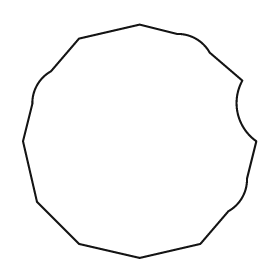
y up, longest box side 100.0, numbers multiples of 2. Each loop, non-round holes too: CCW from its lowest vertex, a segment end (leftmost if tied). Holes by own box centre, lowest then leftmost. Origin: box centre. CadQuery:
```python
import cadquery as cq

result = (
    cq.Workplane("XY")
    .moveTo(0.0, -50.0)
    .lineTo(26.0, -44.0)
    .lineTo(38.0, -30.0)
    .threePointArc((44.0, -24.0), (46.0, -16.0))
    .lineTo(50.0, 0.0)
    .threePointArc((42.0, 12.0), (44.0, 26.0))
    .lineTo(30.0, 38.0)
    .threePointArc((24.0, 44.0), (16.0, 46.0))
    .lineTo(0.0, 50.0)
    .lineTo(-26.0, 44.0)
    .lineTo(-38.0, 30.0)
    .threePointArc((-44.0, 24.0), (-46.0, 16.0))
    .lineTo(-50.0, 0.0)
    .lineTo(-44.0, -26.0)
    .lineTo(-26.0, -44.0)
    .close()
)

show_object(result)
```